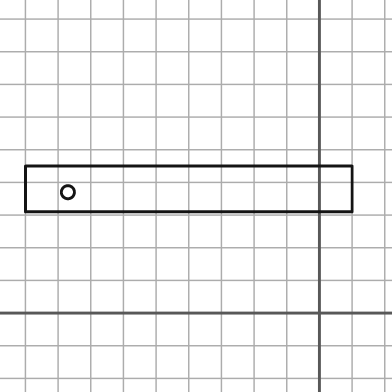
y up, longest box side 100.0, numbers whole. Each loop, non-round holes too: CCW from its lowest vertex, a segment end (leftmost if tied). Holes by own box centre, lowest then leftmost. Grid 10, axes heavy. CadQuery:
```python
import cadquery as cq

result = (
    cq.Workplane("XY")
    .moveTo(-90.0, 31.0)
    .lineTo(10.0, 31.0)
    .lineTo(10.0, 45.0)
    .lineTo(-90.0, 45.0)
    .close()
    .moveTo(-77.0, 37.0)
    .circle(2.0)
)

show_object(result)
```